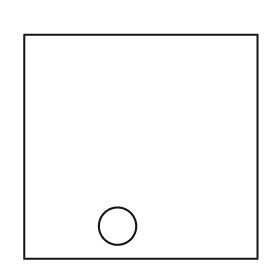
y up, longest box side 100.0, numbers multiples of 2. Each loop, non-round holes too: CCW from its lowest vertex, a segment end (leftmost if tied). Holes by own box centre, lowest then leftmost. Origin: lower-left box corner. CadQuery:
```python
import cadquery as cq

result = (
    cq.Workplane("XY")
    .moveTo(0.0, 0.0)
    .lineTo(100.0, 0.0)
    .lineTo(100.0, 96.0)
    .lineTo(0.0, 96.0)
    .close()
    .moveTo(40.0, 14.0)
    .circle(8.0)
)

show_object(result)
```